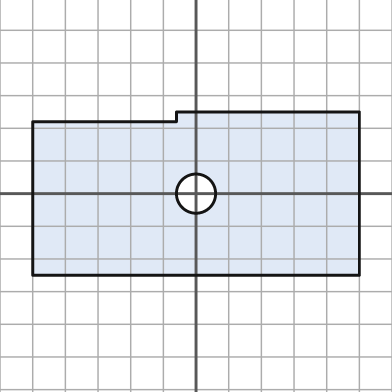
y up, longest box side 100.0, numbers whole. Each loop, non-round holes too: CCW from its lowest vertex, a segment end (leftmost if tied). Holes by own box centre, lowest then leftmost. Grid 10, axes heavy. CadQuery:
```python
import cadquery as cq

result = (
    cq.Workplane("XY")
    .moveTo(-50.0, -25.0)
    .lineTo(50.0, -25.0)
    .lineTo(50.0, 25.0)
    .lineTo(-6.0, 25.0)
    .lineTo(-6.0, 22.0)
    .lineTo(-50.0, 22.0)
    .close()
    .moveTo(0.0, 0.0)
    .circle(6.0)
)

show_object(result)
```